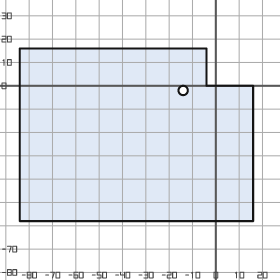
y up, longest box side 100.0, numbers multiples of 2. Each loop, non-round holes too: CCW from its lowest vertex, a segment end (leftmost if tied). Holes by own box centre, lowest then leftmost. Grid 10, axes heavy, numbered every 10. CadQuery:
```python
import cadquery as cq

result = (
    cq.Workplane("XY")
    .moveTo(-84.0, -58.0)
    .lineTo(16.0, -58.0)
    .lineTo(16.0, 0.0)
    .lineTo(-4.0, 0.0)
    .lineTo(-4.0, 16.0)
    .lineTo(-84.0, 16.0)
    .close()
    .moveTo(-14.0, -2.0)
    .circle(2.0)
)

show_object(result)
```